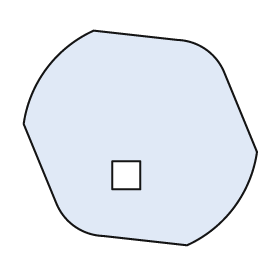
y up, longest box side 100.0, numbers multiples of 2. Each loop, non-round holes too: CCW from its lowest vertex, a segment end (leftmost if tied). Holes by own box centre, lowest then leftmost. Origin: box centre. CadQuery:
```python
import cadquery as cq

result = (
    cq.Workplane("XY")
    .moveTo(20.0, -46.0)
    .threePointArc((40.0, -30.0), (50.0, -6.0))
    .lineTo(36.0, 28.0)
    .threePointArc((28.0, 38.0), (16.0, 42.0))
    .lineTo(-20.0, 46.0)
    .threePointArc((-40.0, 30.0), (-50.0, 6.0))
    .lineTo(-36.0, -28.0)
    .threePointArc((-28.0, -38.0), (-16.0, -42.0))
    .close()
    .moveTo(-12.0, -22.0)
    .lineTo(0.0, -22.0)
    .lineTo(0.0, -10.0)
    .lineTo(-12.0, -10.0)
    .close()
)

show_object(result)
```